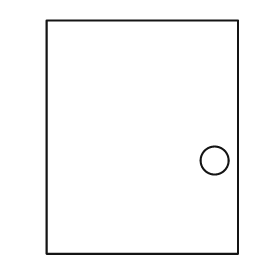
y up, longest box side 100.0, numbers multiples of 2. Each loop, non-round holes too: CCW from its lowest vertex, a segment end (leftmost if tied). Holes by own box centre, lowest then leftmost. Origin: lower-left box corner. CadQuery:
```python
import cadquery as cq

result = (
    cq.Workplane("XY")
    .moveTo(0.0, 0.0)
    .lineTo(82.0, 0.0)
    .lineTo(82.0, 100.0)
    .lineTo(0.0, 100.0)
    .close()
    .moveTo(72.0, 40.0)
    .circle(6.0)
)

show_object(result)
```